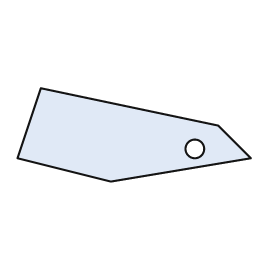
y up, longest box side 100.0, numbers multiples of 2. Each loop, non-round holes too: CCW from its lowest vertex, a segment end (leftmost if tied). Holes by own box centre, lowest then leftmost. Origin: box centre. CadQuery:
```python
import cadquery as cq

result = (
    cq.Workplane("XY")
    .moveTo(-10.0, -20.0)
    .lineTo(50.0, -10.0)
    .lineTo(36.0, 4.0)
    .lineTo(-40.0, 20.0)
    .lineTo(-50.0, -10.0)
    .close()
    .moveTo(26.0, -6.0)
    .circle(4.0)
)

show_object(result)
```